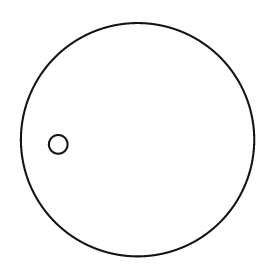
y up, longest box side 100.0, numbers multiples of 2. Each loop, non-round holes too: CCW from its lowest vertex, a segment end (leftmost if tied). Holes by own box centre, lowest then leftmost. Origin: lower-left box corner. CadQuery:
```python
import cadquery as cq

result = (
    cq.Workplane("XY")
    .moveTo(50.0, 50.0)
    .circle(50.0)
    .moveTo(16.0, 48.0)
    .circle(4.0)
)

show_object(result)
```